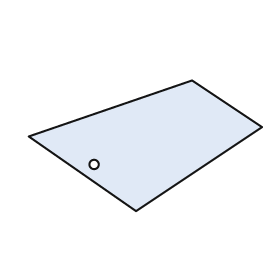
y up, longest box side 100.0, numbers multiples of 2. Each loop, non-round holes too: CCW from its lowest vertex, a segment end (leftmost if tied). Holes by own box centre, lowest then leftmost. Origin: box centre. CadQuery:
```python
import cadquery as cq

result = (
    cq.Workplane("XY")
    .moveTo(-4.0, -28.0)
    .lineTo(50.0, 8.0)
    .lineTo(20.0, 28.0)
    .lineTo(-50.0, 4.0)
    .close()
    .moveTo(-22.0, -8.0)
    .circle(2.0)
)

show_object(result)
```